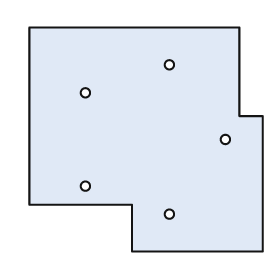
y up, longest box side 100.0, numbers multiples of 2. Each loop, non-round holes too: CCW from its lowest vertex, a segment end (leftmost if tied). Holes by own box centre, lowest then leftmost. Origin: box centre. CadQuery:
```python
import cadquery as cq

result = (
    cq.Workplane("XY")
    .moveTo(-6.0, -48.0)
    .lineTo(50.0, -48.0)
    .lineTo(50.0, 10.0)
    .lineTo(40.0, 10.0)
    .lineTo(40.0, 48.0)
    .lineTo(-50.0, 48.0)
    .lineTo(-50.0, -28.0)
    .lineTo(-6.0, -28.0)
    .close()
    .moveTo(10.0, -32.0)
    .circle(2.0)
    .moveTo(-26.0, -20.0)
    .circle(2.0)
    .moveTo(34.0, 0.0)
    .circle(2.0)
    .moveTo(-26.0, 20.0)
    .circle(2.0)
    .moveTo(10.0, 32.0)
    .circle(2.0)
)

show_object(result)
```